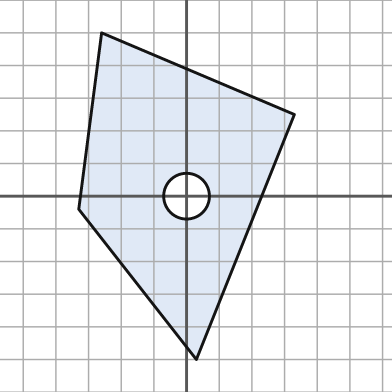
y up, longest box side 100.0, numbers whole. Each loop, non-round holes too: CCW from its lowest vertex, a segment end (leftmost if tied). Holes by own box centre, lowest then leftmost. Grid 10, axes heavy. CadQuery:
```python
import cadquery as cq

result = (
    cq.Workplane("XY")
    .moveTo(3.0, -50.0)
    .lineTo(33.0, 25.0)
    .lineTo(-26.0, 50.0)
    .lineTo(-33.0, -4.0)
    .close()
    .moveTo(0.0, 0.0)
    .circle(7.0)
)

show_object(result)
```